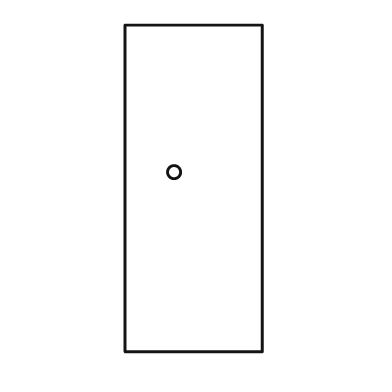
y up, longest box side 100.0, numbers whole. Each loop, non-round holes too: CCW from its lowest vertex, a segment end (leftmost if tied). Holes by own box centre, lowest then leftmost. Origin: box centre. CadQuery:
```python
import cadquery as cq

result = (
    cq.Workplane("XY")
    .moveTo(-21.0, -50.0)
    .lineTo(21.0, -50.0)
    .lineTo(21.0, 50.0)
    .lineTo(-21.0, 50.0)
    .close()
    .moveTo(-6.0, 5.0)
    .circle(2.0)
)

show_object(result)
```